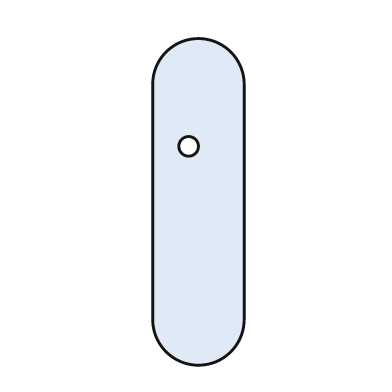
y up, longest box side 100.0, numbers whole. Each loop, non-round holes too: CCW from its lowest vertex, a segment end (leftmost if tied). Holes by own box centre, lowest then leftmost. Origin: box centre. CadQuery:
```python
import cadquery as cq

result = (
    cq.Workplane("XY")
    .moveTo(-14.0, -36.0)
    .threePointArc((0.0, -50.0), (14.0, -36.0))
    .lineTo(14.0, 36.0)
    .threePointArc((0.0, 50.0), (-14.0, 36.0))
    .close()
    .moveTo(-3.0, 17.0)
    .circle(3.0)
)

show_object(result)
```